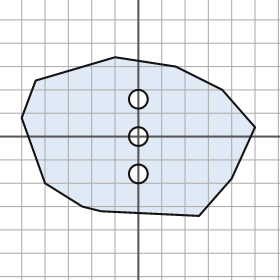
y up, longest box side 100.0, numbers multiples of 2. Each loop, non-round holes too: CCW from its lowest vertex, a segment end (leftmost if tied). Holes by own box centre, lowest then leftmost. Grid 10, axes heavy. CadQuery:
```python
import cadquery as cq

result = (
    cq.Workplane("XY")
    .moveTo(26.0, -34.0)
    .lineTo(40.0, -18.0)
    .lineTo(50.0, 4.0)
    .lineTo(36.0, 20.0)
    .lineTo(16.0, 30.0)
    .lineTo(-10.0, 34.0)
    .lineTo(-44.0, 24.0)
    .lineTo(-50.0, 8.0)
    .lineTo(-40.0, -20.0)
    .lineTo(-24.0, -30.0)
    .lineTo(-16.0, -32.0)
    .close()
    .moveTo(0.0, -16.0)
    .circle(4.0)
    .moveTo(0.0, 0.0)
    .circle(4.0)
    .moveTo(0.0, 16.0)
    .circle(4.0)
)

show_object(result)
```